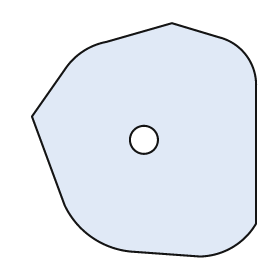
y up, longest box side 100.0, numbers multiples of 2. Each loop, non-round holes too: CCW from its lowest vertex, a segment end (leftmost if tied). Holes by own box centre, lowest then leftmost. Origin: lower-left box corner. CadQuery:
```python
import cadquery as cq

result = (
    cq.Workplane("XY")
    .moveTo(72.0, 0.0)
    .threePointArc((86.0, 4.0), (96.0, 14.0))
    .lineTo(96.0, 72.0)
    .threePointArc((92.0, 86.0), (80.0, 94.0))
    .lineTo(60.0, 100.0)
    .lineTo(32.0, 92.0)
    .threePointArc((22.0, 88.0), (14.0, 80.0))
    .lineTo(0.0, 60.0)
    .lineTo(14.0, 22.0)
    .threePointArc((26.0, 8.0), (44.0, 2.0))
    .close()
    .moveTo(48.0, 50.0)
    .circle(6.0)
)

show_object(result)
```